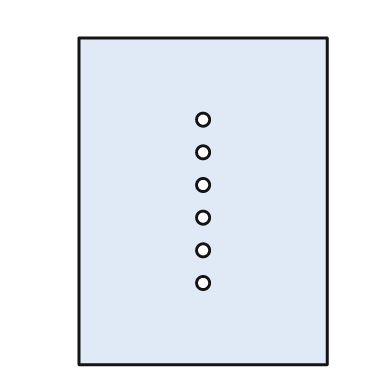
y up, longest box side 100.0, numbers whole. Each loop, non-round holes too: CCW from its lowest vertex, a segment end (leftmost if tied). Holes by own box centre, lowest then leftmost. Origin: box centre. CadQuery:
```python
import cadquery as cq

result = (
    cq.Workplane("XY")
    .moveTo(-38.0, -50.0)
    .lineTo(38.0, -50.0)
    .lineTo(38.0, 50.0)
    .lineTo(-38.0, 50.0)
    .close()
    .moveTo(0.0, -25.0)
    .circle(2.0)
    .moveTo(0.0, -15.0)
    .circle(2.0)
    .moveTo(0.0, -5.0)
    .circle(2.0)
    .moveTo(0.0, 5.0)
    .circle(2.0)
    .moveTo(0.0, 15.0)
    .circle(2.0)
    .moveTo(0.0, 25.0)
    .circle(2.0)
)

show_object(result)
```